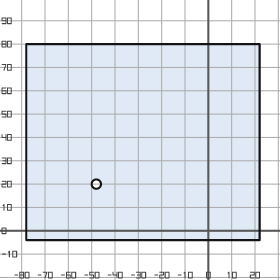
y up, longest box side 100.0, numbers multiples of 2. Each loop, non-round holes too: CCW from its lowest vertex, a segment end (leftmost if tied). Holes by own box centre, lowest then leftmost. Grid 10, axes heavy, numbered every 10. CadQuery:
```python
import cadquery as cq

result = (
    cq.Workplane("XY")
    .moveTo(-78.0, -4.0)
    .lineTo(22.0, -4.0)
    .lineTo(22.0, 80.0)
    .lineTo(-78.0, 80.0)
    .close()
    .moveTo(-48.0, 20.0)
    .circle(2.0)
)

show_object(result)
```